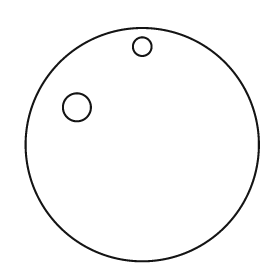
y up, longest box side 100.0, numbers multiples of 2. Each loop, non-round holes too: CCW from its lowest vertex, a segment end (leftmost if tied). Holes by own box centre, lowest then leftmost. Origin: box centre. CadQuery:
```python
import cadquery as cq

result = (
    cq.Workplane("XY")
    .moveTo(0.0, 0.0)
    .circle(50.0)
    .moveTo(-28.0, 16.0)
    .circle(6.0)
    .moveTo(0.0, 42.0)
    .circle(4.0)
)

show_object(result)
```